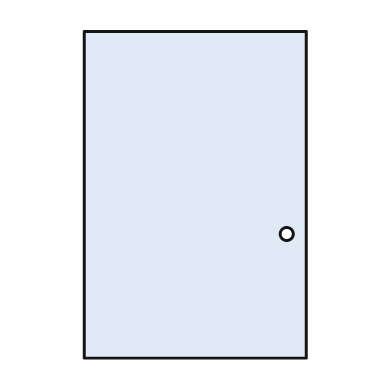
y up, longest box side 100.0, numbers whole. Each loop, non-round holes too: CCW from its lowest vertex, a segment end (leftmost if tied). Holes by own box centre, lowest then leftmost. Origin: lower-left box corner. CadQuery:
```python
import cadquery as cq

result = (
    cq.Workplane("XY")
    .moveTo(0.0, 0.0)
    .lineTo(68.0, 0.0)
    .lineTo(68.0, 100.0)
    .lineTo(0.0, 100.0)
    .close()
    .moveTo(62.0, 38.0)
    .circle(2.0)
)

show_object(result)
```